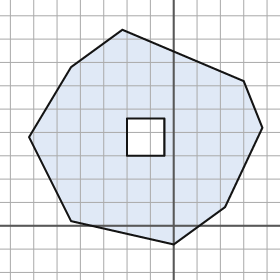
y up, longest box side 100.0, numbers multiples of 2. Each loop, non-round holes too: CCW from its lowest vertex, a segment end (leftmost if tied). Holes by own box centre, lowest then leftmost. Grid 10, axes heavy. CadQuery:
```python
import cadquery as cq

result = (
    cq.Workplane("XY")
    .moveTo(0.0, -8.0)
    .lineTo(22.0, 8.0)
    .lineTo(38.0, 42.0)
    .lineTo(30.0, 62.0)
    .lineTo(-22.0, 84.0)
    .lineTo(-44.0, 68.0)
    .lineTo(-62.0, 38.0)
    .lineTo(-44.0, 2.0)
    .close()
    .moveTo(-20.0, 30.0)
    .lineTo(-4.0, 30.0)
    .lineTo(-4.0, 46.0)
    .lineTo(-20.0, 46.0)
    .close()
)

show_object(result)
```